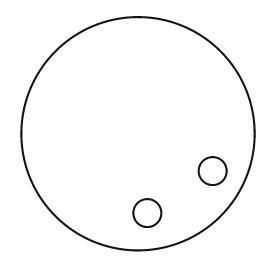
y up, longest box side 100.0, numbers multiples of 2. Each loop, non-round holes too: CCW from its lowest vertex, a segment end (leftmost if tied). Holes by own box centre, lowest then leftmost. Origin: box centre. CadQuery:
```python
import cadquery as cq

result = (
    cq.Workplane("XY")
    .moveTo(0.0, 0.0)
    .circle(50.0)
    .moveTo(4.0, -34.0)
    .circle(6.0)
    .moveTo(32.0, -16.0)
    .circle(6.0)
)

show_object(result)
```